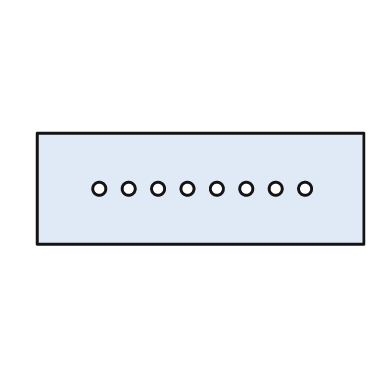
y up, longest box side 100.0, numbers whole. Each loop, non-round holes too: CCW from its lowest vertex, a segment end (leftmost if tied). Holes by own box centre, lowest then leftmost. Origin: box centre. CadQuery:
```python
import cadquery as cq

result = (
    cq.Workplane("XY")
    .moveTo(-50.0, -17.0)
    .lineTo(50.0, -17.0)
    .lineTo(50.0, 17.0)
    .lineTo(-50.0, 17.0)
    .close()
    .moveTo(-31.0, 0.0)
    .circle(2.0)
    .moveTo(-22.0, 0.0)
    .circle(2.0)
    .moveTo(-13.0, 0.0)
    .circle(2.0)
    .moveTo(-4.0, 0.0)
    .circle(2.0)
    .moveTo(5.0, 0.0)
    .circle(2.0)
    .moveTo(14.0, 0.0)
    .circle(2.0)
    .moveTo(23.0, 0.0)
    .circle(2.0)
    .moveTo(32.0, 0.0)
    .circle(2.0)
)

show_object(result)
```